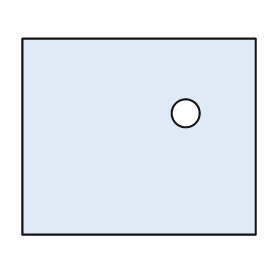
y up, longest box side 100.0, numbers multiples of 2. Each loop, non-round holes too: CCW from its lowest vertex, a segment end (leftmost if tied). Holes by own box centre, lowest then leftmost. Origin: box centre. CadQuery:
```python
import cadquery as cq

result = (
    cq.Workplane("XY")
    .moveTo(-50.0, -42.0)
    .lineTo(50.0, -42.0)
    .lineTo(50.0, 42.0)
    .lineTo(-50.0, 42.0)
    .close()
    .moveTo(20.0, 10.0)
    .circle(6.0)
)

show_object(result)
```